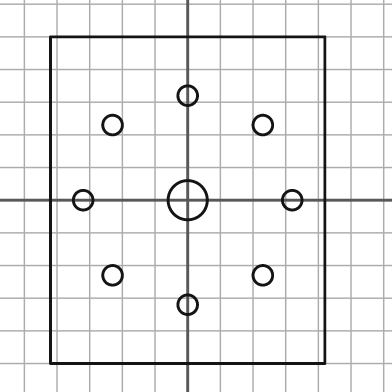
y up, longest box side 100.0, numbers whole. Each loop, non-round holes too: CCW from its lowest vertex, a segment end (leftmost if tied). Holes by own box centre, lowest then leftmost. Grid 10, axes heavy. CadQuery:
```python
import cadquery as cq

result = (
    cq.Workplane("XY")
    .moveTo(-42.0, -50.0)
    .lineTo(42.0, -50.0)
    .lineTo(42.0, 50.0)
    .lineTo(-42.0, 50.0)
    .close()
    .moveTo(0.0, -32.0)
    .circle(3.0)
    .moveTo(-23.0, -23.0)
    .circle(3.0)
    .moveTo(23.0, -23.0)
    .circle(3.0)
    .moveTo(-32.0, 0.0)
    .circle(3.0)
    .moveTo(0.0, 0.0)
    .circle(6.0)
    .moveTo(32.0, 0.0)
    .circle(3.0)
    .moveTo(-23.0, 23.0)
    .circle(3.0)
    .moveTo(23.0, 23.0)
    .circle(3.0)
    .moveTo(0.0, 32.0)
    .circle(3.0)
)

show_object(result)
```